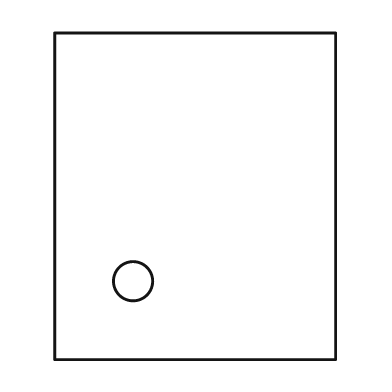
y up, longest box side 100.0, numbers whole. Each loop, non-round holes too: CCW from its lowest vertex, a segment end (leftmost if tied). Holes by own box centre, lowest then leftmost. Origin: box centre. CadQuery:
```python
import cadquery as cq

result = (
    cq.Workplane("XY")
    .moveTo(-43.0, -50.0)
    .lineTo(43.0, -50.0)
    .lineTo(43.0, 50.0)
    .lineTo(-43.0, 50.0)
    .close()
    .moveTo(-19.0, -26.0)
    .circle(6.0)
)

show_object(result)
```